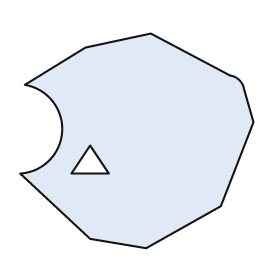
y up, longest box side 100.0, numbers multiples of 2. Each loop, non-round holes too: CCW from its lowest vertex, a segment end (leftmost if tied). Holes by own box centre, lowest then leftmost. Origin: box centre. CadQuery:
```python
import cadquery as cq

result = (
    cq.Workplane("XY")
    .moveTo(4.0, -46.0)
    .lineTo(36.0, -28.0)
    .lineTo(50.0, 8.0)
    .lineTo(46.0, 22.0)
    .threePointArc((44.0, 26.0), (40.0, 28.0))
    .lineTo(6.0, 46.0)
    .lineTo(-22.0, 40.0)
    .lineTo(-48.0, 24.0)
    .threePointArc((-32.0, 4.0), (-50.0, -14.0))
    .lineTo(-20.0, -42.0)
    .close()
    .moveTo(-28.0, -14.0)
    .lineTo(-12.0, -14.0)
    .lineTo(-20.0, -2.0)
    .close()
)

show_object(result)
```